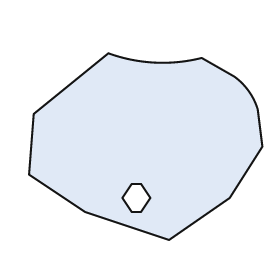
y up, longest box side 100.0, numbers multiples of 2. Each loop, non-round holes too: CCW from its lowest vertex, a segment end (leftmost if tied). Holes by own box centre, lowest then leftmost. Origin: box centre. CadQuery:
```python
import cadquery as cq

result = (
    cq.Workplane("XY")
    .moveTo(10.0, -40.0)
    .lineTo(36.0, -22.0)
    .lineTo(50.0, 0.0)
    .lineTo(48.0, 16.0)
    .threePointArc((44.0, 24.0), (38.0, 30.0))
    .lineTo(24.0, 38.0)
    .threePointArc((4.0, 36.0), (-16.0, 40.0))
    .lineTo(-48.0, 14.0)
    .lineTo(-50.0, -12.0)
    .lineTo(-26.0, -28.0)
    .close()
    .moveTo(-6.0, -28.0)
    .lineTo(-2.0, -28.0)
    .lineTo(2.0, -22.0)
    .lineTo(-2.0, -16.0)
    .lineTo(-6.0, -16.0)
    .lineTo(-10.0, -22.0)
    .close()
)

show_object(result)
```